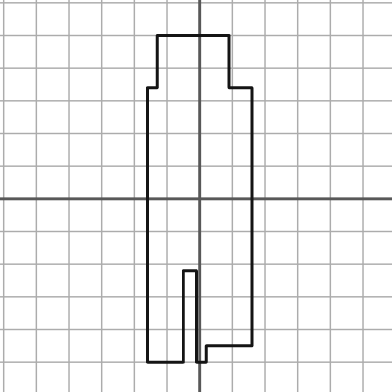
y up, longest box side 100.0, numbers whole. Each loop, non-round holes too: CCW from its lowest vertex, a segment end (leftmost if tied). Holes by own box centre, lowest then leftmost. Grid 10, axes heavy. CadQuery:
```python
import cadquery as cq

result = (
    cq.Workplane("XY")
    .moveTo(-16.0, -50.0)
    .lineTo(-5.0, -50.0)
    .lineTo(-5.0, -22.0)
    .lineTo(-1.0, -22.0)
    .lineTo(-1.0, -50.0)
    .lineTo(2.0, -50.0)
    .lineTo(2.0, -45.0)
    .lineTo(16.0, -45.0)
    .lineTo(16.0, 34.0)
    .lineTo(9.0, 34.0)
    .lineTo(9.0, 50.0)
    .lineTo(-13.0, 50.0)
    .lineTo(-13.0, 34.0)
    .lineTo(-16.0, 34.0)
    .close()
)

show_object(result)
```